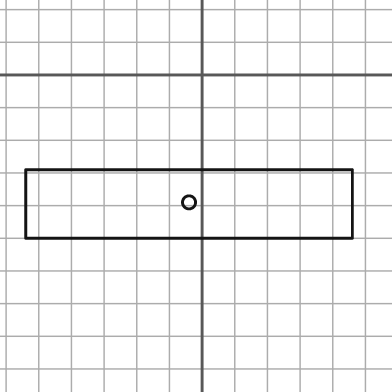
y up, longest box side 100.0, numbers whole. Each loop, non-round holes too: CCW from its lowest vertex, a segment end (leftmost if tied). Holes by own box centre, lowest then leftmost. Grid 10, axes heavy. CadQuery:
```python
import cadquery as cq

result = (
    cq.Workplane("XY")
    .moveTo(-54.0, -50.0)
    .lineTo(46.0, -50.0)
    .lineTo(46.0, -29.0)
    .lineTo(-54.0, -29.0)
    .close()
    .moveTo(-4.0, -39.0)
    .circle(2.0)
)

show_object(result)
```